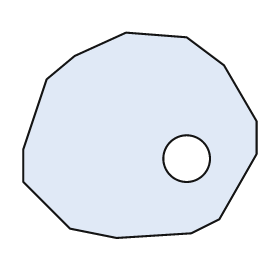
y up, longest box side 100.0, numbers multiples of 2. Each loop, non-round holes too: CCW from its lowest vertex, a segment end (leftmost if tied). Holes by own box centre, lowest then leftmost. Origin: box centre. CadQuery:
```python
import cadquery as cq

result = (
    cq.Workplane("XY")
    .moveTo(-10.0, -44.0)
    .lineTo(22.0, -42.0)
    .lineTo(34.0, -36.0)
    .lineTo(50.0, -8.0)
    .lineTo(50.0, 6.0)
    .lineTo(36.0, 30.0)
    .lineTo(20.0, 42.0)
    .lineTo(-6.0, 44.0)
    .lineTo(-28.0, 34.0)
    .lineTo(-40.0, 24.0)
    .lineTo(-50.0, -6.0)
    .lineTo(-50.0, -20.0)
    .lineTo(-30.0, -40.0)
    .close()
    .moveTo(20.0, -10.0)
    .circle(10.0)
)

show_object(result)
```